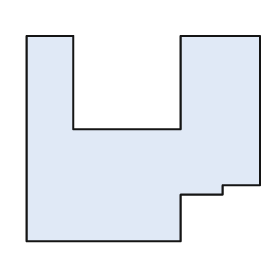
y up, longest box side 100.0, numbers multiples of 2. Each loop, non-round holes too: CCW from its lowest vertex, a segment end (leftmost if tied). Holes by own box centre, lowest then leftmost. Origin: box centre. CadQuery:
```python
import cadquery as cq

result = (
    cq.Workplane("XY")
    .moveTo(-50.0, -44.0)
    .lineTo(16.0, -44.0)
    .lineTo(16.0, -24.0)
    .lineTo(34.0, -24.0)
    .lineTo(34.0, -20.0)
    .lineTo(50.0, -20.0)
    .lineTo(50.0, 44.0)
    .lineTo(16.0, 44.0)
    .lineTo(16.0, 4.0)
    .lineTo(-30.0, 4.0)
    .lineTo(-30.0, 44.0)
    .lineTo(-50.0, 44.0)
    .close()
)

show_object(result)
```